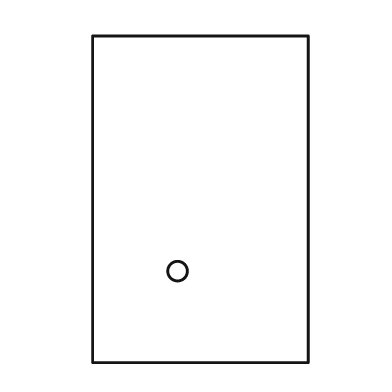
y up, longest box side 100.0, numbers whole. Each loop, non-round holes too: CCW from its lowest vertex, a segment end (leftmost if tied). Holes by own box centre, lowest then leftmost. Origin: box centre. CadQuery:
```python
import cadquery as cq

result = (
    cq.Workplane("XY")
    .moveTo(-33.0, -50.0)
    .lineTo(33.0, -50.0)
    .lineTo(33.0, 50.0)
    .lineTo(-33.0, 50.0)
    .close()
    .moveTo(-7.0, -22.0)
    .circle(3.0)
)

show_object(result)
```